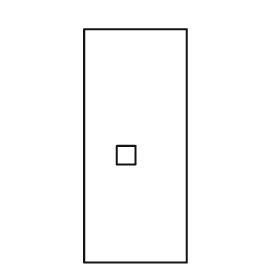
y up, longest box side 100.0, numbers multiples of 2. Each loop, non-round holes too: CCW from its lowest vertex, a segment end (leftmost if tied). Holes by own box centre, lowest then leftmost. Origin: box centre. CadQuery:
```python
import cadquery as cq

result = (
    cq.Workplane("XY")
    .moveTo(-22.0, -50.0)
    .lineTo(22.0, -50.0)
    .lineTo(22.0, 50.0)
    .lineTo(-22.0, 50.0)
    .close()
    .moveTo(-8.0, -8.0)
    .lineTo(0.0, -8.0)
    .lineTo(0.0, 0.0)
    .lineTo(-8.0, 0.0)
    .close()
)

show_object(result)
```